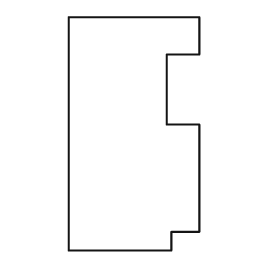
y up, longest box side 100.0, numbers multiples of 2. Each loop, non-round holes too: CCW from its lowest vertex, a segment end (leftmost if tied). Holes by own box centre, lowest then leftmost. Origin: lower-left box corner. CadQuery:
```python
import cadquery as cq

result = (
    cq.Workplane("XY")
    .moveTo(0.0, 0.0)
    .lineTo(44.0, 0.0)
    .lineTo(44.0, 8.0)
    .lineTo(56.0, 8.0)
    .lineTo(56.0, 54.0)
    .lineTo(42.0, 54.0)
    .lineTo(42.0, 84.0)
    .lineTo(56.0, 84.0)
    .lineTo(56.0, 100.0)
    .lineTo(0.0, 100.0)
    .close()
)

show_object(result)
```